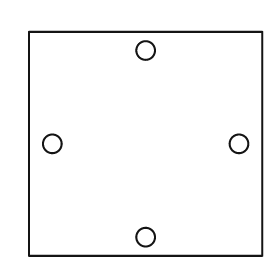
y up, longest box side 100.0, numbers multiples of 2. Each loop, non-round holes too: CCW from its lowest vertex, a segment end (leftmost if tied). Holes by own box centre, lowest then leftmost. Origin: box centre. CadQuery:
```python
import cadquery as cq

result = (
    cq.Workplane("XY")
    .moveTo(-50.0, -48.0)
    .lineTo(50.0, -48.0)
    .lineTo(50.0, 48.0)
    .lineTo(-50.0, 48.0)
    .close()
    .moveTo(0.0, -40.0)
    .circle(4.0)
    .moveTo(-40.0, 0.0)
    .circle(4.0)
    .moveTo(40.0, 0.0)
    .circle(4.0)
    .moveTo(0.0, 40.0)
    .circle(4.0)
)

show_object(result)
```